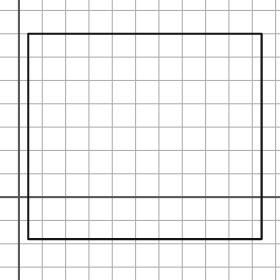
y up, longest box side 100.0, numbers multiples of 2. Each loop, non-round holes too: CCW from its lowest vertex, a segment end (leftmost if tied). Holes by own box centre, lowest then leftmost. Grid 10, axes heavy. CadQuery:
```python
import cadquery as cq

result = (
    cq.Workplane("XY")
    .moveTo(4.0, -18.0)
    .lineTo(104.0, -18.0)
    .lineTo(104.0, 70.0)
    .lineTo(4.0, 70.0)
    .close()
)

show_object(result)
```